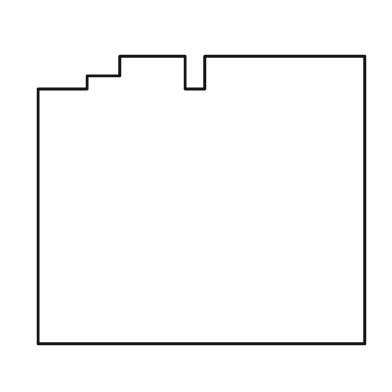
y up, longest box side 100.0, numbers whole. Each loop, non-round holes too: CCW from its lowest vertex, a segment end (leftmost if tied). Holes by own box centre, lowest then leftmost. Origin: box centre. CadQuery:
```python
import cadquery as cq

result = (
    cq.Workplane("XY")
    .moveTo(-50.0, -44.0)
    .lineTo(50.0, -44.0)
    .lineTo(50.0, 44.0)
    .lineTo(1.0, 44.0)
    .lineTo(1.0, 34.0)
    .lineTo(-5.0, 34.0)
    .lineTo(-5.0, 44.0)
    .lineTo(-25.0, 44.0)
    .lineTo(-25.0, 38.0)
    .lineTo(-35.0, 38.0)
    .lineTo(-35.0, 34.0)
    .lineTo(-50.0, 34.0)
    .close()
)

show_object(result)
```